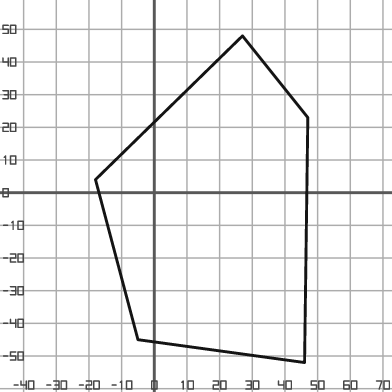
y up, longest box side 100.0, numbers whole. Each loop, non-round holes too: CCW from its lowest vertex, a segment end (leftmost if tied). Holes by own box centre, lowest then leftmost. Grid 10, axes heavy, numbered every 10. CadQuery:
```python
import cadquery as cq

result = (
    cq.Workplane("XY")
    .moveTo(46.0, -52.0)
    .lineTo(47.0, 23.0)
    .lineTo(27.0, 48.0)
    .lineTo(-18.0, 4.0)
    .lineTo(-5.0, -45.0)
    .close()
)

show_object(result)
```